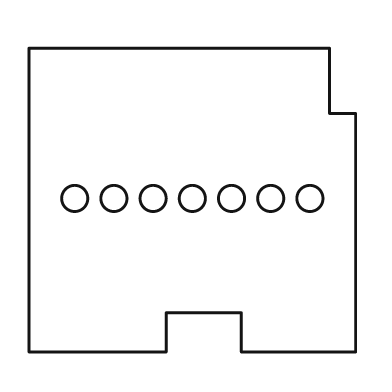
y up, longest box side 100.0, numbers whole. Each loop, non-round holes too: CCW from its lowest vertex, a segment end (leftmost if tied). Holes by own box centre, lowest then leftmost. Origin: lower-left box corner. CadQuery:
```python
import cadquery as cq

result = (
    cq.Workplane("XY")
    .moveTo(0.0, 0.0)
    .lineTo(42.0, 0.0)
    .lineTo(42.0, 12.0)
    .lineTo(65.0, 12.0)
    .lineTo(65.0, 0.0)
    .lineTo(100.0, 0.0)
    .lineTo(100.0, 73.0)
    .lineTo(92.0, 73.0)
    .lineTo(92.0, 93.0)
    .lineTo(0.0, 93.0)
    .close()
    .moveTo(14.0, 47.0)
    .circle(4.0)
    .moveTo(26.0, 47.0)
    .circle(4.0)
    .moveTo(38.0, 47.0)
    .circle(4.0)
    .moveTo(50.0, 47.0)
    .circle(4.0)
    .moveTo(62.0, 47.0)
    .circle(4.0)
    .moveTo(74.0, 47.0)
    .circle(4.0)
    .moveTo(86.0, 47.0)
    .circle(4.0)
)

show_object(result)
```